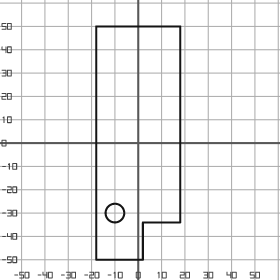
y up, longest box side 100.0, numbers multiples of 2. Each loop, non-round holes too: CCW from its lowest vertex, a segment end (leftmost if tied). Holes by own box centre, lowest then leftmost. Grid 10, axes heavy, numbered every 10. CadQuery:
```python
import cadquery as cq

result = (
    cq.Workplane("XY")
    .moveTo(-18.0, -50.0)
    .lineTo(2.0, -50.0)
    .lineTo(2.0, -34.0)
    .lineTo(18.0, -34.0)
    .lineTo(18.0, 50.0)
    .lineTo(-18.0, 50.0)
    .close()
    .moveTo(-10.0, -30.0)
    .circle(4.0)
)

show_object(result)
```